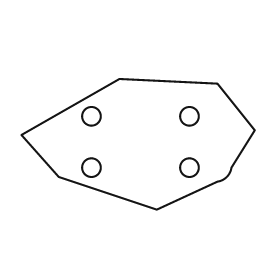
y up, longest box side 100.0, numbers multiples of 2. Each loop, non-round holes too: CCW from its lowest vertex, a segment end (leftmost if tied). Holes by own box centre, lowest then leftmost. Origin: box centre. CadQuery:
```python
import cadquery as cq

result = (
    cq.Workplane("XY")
    .moveTo(8.0, -28.0)
    .lineTo(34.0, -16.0)
    .threePointArc((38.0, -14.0), (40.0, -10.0))
    .lineTo(50.0, 6.0)
    .lineTo(34.0, 26.0)
    .lineTo(-8.0, 28.0)
    .lineTo(-50.0, 4.0)
    .lineTo(-34.0, -14.0)
    .close()
    .moveTo(-20.0, -10.0)
    .circle(4.0)
    .moveTo(22.0, -10.0)
    .circle(4.0)
    .moveTo(-20.0, 12.0)
    .circle(4.0)
    .moveTo(22.0, 12.0)
    .circle(4.0)
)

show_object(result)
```